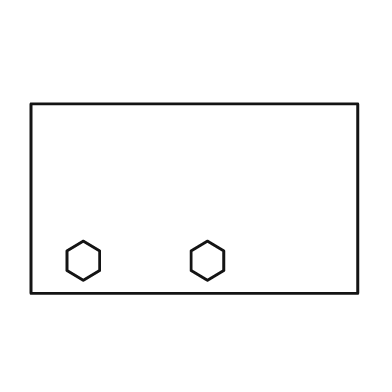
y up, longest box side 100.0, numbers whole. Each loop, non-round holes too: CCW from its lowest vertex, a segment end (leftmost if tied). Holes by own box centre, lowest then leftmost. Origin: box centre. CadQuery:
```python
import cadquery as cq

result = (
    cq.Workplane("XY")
    .moveTo(-50.0, -29.0)
    .lineTo(50.0, -29.0)
    .lineTo(50.0, 29.0)
    .lineTo(-50.0, 29.0)
    .close()
    .moveTo(-34.0, -25.0)
    .lineTo(-29.0, -22.0)
    .lineTo(-29.0, -16.0)
    .lineTo(-34.0, -13.0)
    .lineTo(-39.0, -16.0)
    .lineTo(-39.0, -22.0)
    .close()
    .moveTo(4.0, -25.0)
    .lineTo(9.0, -22.0)
    .lineTo(9.0, -16.0)
    .lineTo(4.0, -13.0)
    .lineTo(-1.0, -16.0)
    .lineTo(-1.0, -22.0)
    .close()
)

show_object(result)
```